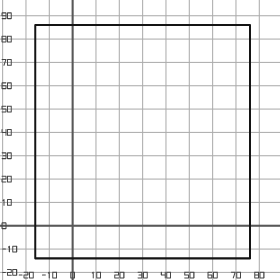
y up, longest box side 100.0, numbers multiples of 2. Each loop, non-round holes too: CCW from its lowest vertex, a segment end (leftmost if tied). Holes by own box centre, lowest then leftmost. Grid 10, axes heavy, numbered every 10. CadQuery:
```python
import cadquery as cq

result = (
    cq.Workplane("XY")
    .moveTo(-16.0, -14.0)
    .lineTo(76.0, -14.0)
    .lineTo(76.0, 86.0)
    .lineTo(-16.0, 86.0)
    .close()
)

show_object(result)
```